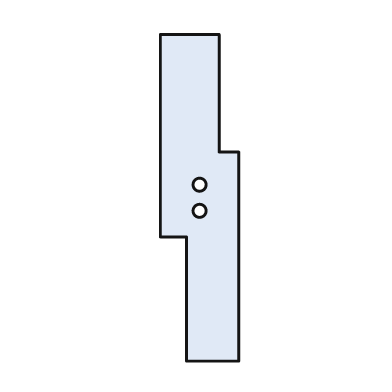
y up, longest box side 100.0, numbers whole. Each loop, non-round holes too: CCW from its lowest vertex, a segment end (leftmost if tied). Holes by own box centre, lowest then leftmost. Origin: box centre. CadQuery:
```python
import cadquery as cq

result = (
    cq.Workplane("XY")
    .moveTo(-4.0, -50.0)
    .lineTo(12.0, -50.0)
    .lineTo(12.0, 14.0)
    .lineTo(6.0, 14.0)
    .lineTo(6.0, 50.0)
    .lineTo(-12.0, 50.0)
    .lineTo(-12.0, -12.0)
    .lineTo(-4.0, -12.0)
    .close()
    .moveTo(0.0, -4.0)
    .circle(2.0)
    .moveTo(0.0, 4.0)
    .circle(2.0)
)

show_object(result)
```